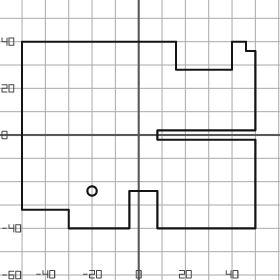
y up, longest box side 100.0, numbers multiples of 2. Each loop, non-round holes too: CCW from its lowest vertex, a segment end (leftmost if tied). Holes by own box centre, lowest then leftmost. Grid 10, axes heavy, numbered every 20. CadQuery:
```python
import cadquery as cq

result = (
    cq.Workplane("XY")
    .moveTo(-30.0, -40.0)
    .lineTo(-4.0, -40.0)
    .lineTo(-4.0, -24.0)
    .lineTo(8.0, -24.0)
    .lineTo(8.0, -40.0)
    .lineTo(50.0, -40.0)
    .lineTo(50.0, -2.0)
    .lineTo(8.0, -2.0)
    .lineTo(8.0, 2.0)
    .lineTo(50.0, 2.0)
    .lineTo(50.0, 36.0)
    .lineTo(46.0, 36.0)
    .lineTo(46.0, 40.0)
    .lineTo(40.0, 40.0)
    .lineTo(40.0, 28.0)
    .lineTo(16.0, 28.0)
    .lineTo(16.0, 40.0)
    .lineTo(-50.0, 40.0)
    .lineTo(-50.0, -32.0)
    .lineTo(-30.0, -32.0)
    .close()
    .moveTo(-20.0, -24.0)
    .circle(2.0)
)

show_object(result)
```